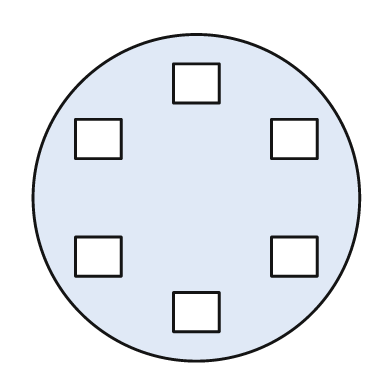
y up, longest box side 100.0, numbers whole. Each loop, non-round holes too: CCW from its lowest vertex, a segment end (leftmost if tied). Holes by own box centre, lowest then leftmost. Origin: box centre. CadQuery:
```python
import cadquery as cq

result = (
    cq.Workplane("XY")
    .moveTo(0.0, 0.0)
    .circle(50.0)
    .moveTo(-7.0, -41.0)
    .lineTo(7.0, -41.0)
    .lineTo(7.0, -29.0)
    .lineTo(-7.0, -29.0)
    .close()
    .moveTo(-37.0, -24.0)
    .lineTo(-23.0, -24.0)
    .lineTo(-23.0, -12.0)
    .lineTo(-37.0, -12.0)
    .close()
    .moveTo(23.0, -24.0)
    .lineTo(37.0, -24.0)
    .lineTo(37.0, -12.0)
    .lineTo(23.0, -12.0)
    .close()
    .moveTo(-37.0, 12.0)
    .lineTo(-23.0, 12.0)
    .lineTo(-23.0, 24.0)
    .lineTo(-37.0, 24.0)
    .close()
    .moveTo(23.0, 12.0)
    .lineTo(37.0, 12.0)
    .lineTo(37.0, 24.0)
    .lineTo(23.0, 24.0)
    .close()
    .moveTo(-7.0, 29.0)
    .lineTo(7.0, 29.0)
    .lineTo(7.0, 41.0)
    .lineTo(-7.0, 41.0)
    .close()
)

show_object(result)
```